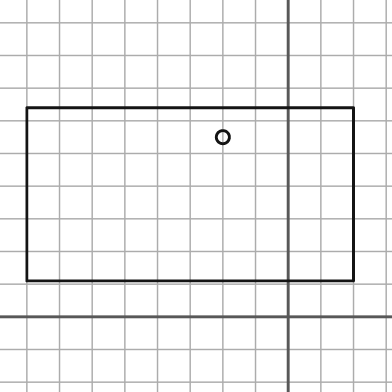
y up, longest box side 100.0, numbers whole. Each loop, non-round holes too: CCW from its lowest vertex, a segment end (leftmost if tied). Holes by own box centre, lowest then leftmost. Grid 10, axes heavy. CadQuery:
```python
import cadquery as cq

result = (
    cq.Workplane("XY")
    .moveTo(-80.0, 11.0)
    .lineTo(20.0, 11.0)
    .lineTo(20.0, 64.0)
    .lineTo(-80.0, 64.0)
    .close()
    .moveTo(-20.0, 55.0)
    .circle(2.0)
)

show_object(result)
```